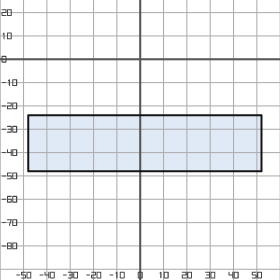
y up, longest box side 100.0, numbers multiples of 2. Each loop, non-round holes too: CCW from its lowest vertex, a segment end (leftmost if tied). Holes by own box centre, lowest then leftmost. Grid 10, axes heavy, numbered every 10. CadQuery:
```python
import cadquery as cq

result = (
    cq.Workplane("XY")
    .moveTo(-48.0, -48.0)
    .lineTo(52.0, -48.0)
    .lineTo(52.0, -24.0)
    .lineTo(-48.0, -24.0)
    .close()
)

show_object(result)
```